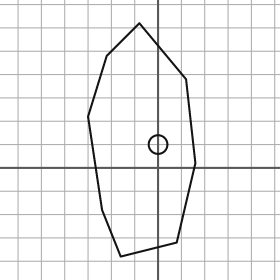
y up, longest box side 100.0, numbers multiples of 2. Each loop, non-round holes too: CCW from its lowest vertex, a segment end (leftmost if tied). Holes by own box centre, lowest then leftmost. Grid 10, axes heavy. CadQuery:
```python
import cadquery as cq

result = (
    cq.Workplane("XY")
    .moveTo(-16.0, -38.0)
    .lineTo(8.0, -32.0)
    .lineTo(16.0, 2.0)
    .lineTo(12.0, 38.0)
    .lineTo(-8.0, 62.0)
    .lineTo(-22.0, 48.0)
    .lineTo(-30.0, 22.0)
    .lineTo(-24.0, -18.0)
    .close()
    .moveTo(0.0, 10.0)
    .circle(4.0)
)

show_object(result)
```